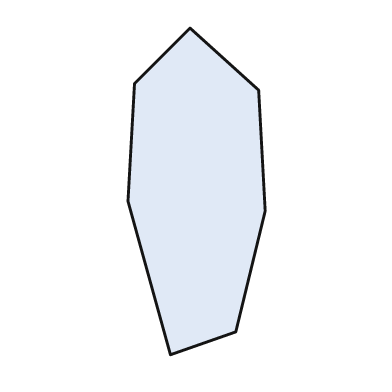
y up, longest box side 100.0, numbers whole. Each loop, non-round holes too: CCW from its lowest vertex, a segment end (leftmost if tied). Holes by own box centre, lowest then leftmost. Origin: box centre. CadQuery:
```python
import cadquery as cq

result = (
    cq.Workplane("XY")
    .moveTo(-8.0, -50.0)
    .lineTo(12.0, -43.0)
    .lineTo(21.0, -6.0)
    .lineTo(19.0, 31.0)
    .lineTo(-2.0, 50.0)
    .lineTo(-19.0, 33.0)
    .lineTo(-21.0, -3.0)
    .close()
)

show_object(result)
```